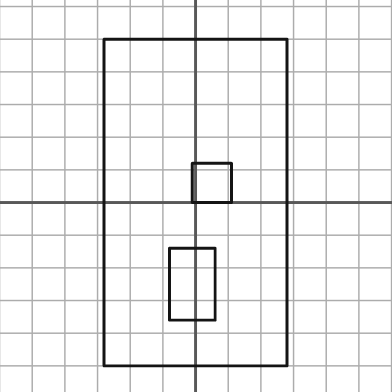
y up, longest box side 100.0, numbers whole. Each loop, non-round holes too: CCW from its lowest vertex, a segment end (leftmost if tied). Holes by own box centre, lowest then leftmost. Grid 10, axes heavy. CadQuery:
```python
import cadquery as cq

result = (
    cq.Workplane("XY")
    .moveTo(-28.0, -50.0)
    .lineTo(28.0, -50.0)
    .lineTo(28.0, 50.0)
    .lineTo(-28.0, 50.0)
    .close()
    .moveTo(-8.0, -36.0)
    .lineTo(6.0, -36.0)
    .lineTo(6.0, -14.0)
    .lineTo(-8.0, -14.0)
    .close()
    .moveTo(-1.0, 0.0)
    .lineTo(11.0, 0.0)
    .lineTo(11.0, 12.0)
    .lineTo(-1.0, 12.0)
    .close()
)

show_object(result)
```